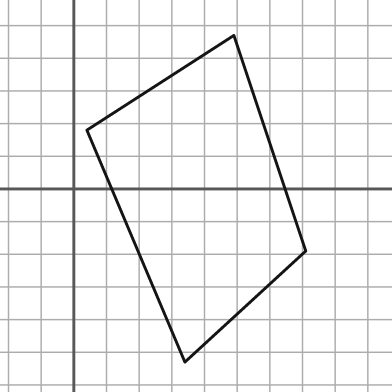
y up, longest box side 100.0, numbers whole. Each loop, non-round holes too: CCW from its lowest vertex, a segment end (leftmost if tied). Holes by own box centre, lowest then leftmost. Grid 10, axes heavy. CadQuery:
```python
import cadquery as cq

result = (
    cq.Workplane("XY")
    .moveTo(34.0, -53.0)
    .lineTo(71.0, -19.0)
    .lineTo(49.0, 47.0)
    .lineTo(4.0, 18.0)
    .close()
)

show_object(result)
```